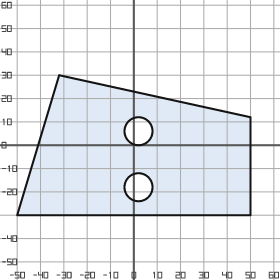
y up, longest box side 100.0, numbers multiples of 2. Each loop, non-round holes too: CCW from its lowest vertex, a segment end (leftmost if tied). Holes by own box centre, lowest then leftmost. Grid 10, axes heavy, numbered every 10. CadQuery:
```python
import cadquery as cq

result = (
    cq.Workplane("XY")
    .moveTo(-50.0, -30.0)
    .lineTo(50.0, -30.0)
    .lineTo(50.0, 12.0)
    .lineTo(-32.0, 30.0)
    .close()
    .moveTo(2.0, -18.0)
    .circle(6.0)
    .moveTo(2.0, 6.0)
    .circle(6.0)
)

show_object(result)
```